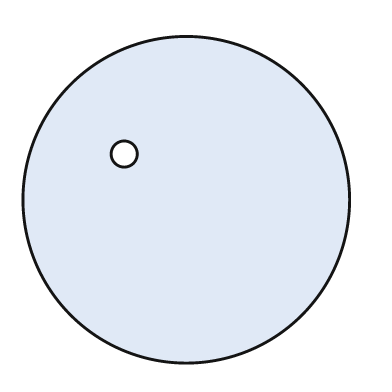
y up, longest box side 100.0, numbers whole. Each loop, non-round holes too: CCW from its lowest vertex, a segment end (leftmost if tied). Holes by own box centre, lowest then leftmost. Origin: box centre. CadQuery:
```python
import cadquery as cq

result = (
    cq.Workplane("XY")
    .moveTo(0.0, 0.0)
    .circle(50.0)
    .moveTo(-19.0, 14.0)
    .circle(4.0)
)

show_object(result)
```